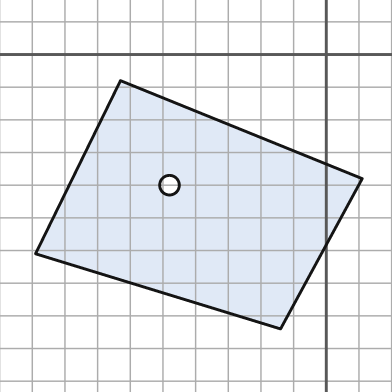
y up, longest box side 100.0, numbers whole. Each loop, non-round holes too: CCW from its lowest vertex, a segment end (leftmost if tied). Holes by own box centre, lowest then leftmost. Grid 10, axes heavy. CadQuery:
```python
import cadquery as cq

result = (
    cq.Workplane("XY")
    .moveTo(-14.0, -84.0)
    .lineTo(11.0, -38.0)
    .lineTo(-63.0, -8.0)
    .lineTo(-89.0, -61.0)
    .close()
    .moveTo(-48.0, -40.0)
    .circle(3.0)
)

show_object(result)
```